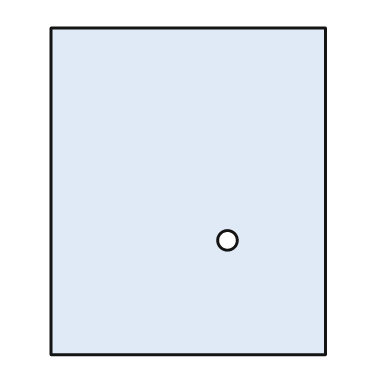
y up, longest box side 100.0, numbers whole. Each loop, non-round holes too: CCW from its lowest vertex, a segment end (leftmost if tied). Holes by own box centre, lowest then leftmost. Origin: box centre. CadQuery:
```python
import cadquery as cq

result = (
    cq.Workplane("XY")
    .moveTo(-42.0, -50.0)
    .lineTo(42.0, -50.0)
    .lineTo(42.0, 50.0)
    .lineTo(-42.0, 50.0)
    .close()
    .moveTo(12.0, -15.0)
    .circle(3.0)
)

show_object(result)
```